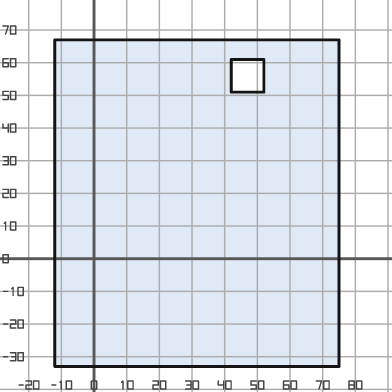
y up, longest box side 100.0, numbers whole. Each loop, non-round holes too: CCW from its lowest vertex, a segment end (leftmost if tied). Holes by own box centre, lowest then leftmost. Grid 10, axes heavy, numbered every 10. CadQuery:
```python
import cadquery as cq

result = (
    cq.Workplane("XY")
    .moveTo(-12.0, -33.0)
    .lineTo(75.0, -33.0)
    .lineTo(75.0, 67.0)
    .lineTo(-12.0, 67.0)
    .close()
    .moveTo(42.0, 51.0)
    .lineTo(52.0, 51.0)
    .lineTo(52.0, 61.0)
    .lineTo(42.0, 61.0)
    .close()
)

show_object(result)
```